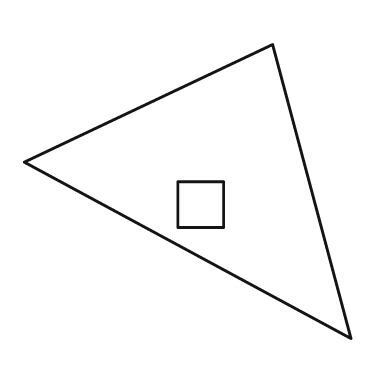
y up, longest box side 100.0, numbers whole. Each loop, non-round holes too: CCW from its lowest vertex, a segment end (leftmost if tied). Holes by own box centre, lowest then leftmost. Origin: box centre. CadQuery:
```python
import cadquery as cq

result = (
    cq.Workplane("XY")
    .moveTo(50.0, -45.0)
    .lineTo(26.0, 45.0)
    .lineTo(-50.0, 9.0)
    .close()
    .moveTo(-3.0, -11.0)
    .lineTo(11.0, -11.0)
    .lineTo(11.0, 3.0)
    .lineTo(-3.0, 3.0)
    .close()
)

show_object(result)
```